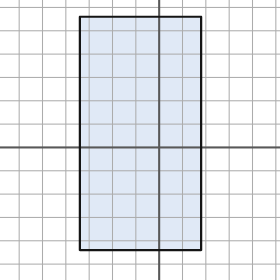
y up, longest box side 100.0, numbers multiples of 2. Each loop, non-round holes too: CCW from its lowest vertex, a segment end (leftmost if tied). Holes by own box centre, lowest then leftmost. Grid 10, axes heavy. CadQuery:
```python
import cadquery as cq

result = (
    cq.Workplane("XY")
    .moveTo(-34.0, -44.0)
    .lineTo(18.0, -44.0)
    .lineTo(18.0, 56.0)
    .lineTo(-34.0, 56.0)
    .close()
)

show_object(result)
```